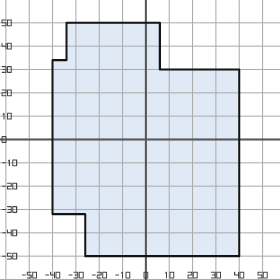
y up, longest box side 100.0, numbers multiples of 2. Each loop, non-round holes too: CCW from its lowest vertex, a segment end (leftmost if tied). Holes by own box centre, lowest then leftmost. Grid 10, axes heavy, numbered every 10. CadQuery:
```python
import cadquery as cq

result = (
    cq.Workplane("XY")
    .moveTo(-26.0, -50.0)
    .lineTo(40.0, -50.0)
    .lineTo(40.0, 30.0)
    .lineTo(6.0, 30.0)
    .lineTo(6.0, 50.0)
    .lineTo(-34.0, 50.0)
    .lineTo(-34.0, 34.0)
    .lineTo(-40.0, 34.0)
    .lineTo(-40.0, -32.0)
    .lineTo(-26.0, -32.0)
    .close()
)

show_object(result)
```